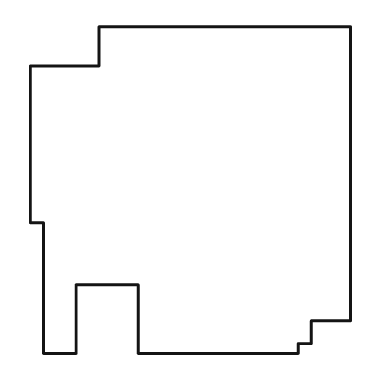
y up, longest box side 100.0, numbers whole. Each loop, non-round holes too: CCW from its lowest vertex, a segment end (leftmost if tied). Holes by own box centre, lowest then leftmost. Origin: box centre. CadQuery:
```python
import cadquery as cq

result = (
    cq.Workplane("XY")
    .moveTo(-45.0, -50.0)
    .lineTo(-35.0, -50.0)
    .lineTo(-35.0, -29.0)
    .lineTo(-16.0, -29.0)
    .lineTo(-16.0, -50.0)
    .lineTo(33.0, -50.0)
    .lineTo(33.0, -47.0)
    .lineTo(37.0, -47.0)
    .lineTo(37.0, -40.0)
    .lineTo(49.0, -40.0)
    .lineTo(49.0, 50.0)
    .lineTo(-28.0, 50.0)
    .lineTo(-28.0, 38.0)
    .lineTo(-49.0, 38.0)
    .lineTo(-49.0, -10.0)
    .lineTo(-45.0, -10.0)
    .close()
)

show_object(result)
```